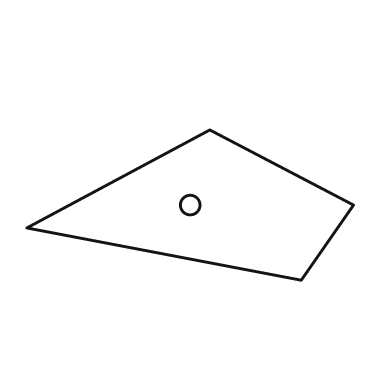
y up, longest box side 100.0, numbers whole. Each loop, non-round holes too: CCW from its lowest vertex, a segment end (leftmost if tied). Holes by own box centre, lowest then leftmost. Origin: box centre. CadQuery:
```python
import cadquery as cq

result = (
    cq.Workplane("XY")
    .moveTo(34.0, -23.0)
    .lineTo(50.0, 0.0)
    .lineTo(6.0, 23.0)
    .lineTo(-50.0, -7.0)
    .close()
    .moveTo(0.0, 0.0)
    .circle(3.0)
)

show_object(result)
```